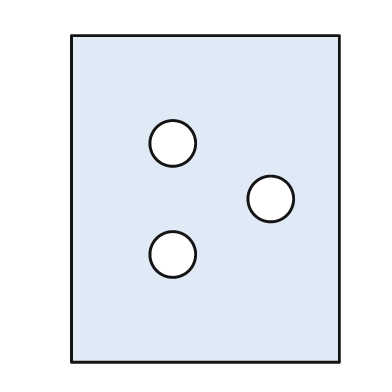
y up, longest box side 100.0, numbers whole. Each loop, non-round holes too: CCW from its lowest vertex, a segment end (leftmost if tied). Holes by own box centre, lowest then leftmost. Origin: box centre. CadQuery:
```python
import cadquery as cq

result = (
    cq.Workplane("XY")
    .moveTo(-41.0, -50.0)
    .lineTo(41.0, -50.0)
    .lineTo(41.0, 50.0)
    .lineTo(-41.0, 50.0)
    .close()
    .moveTo(-10.0, -17.0)
    .circle(7.0)
    .moveTo(20.0, 0.0)
    .circle(7.0)
    .moveTo(-10.0, 17.0)
    .circle(7.0)
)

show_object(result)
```